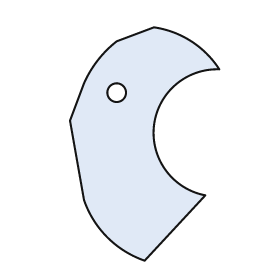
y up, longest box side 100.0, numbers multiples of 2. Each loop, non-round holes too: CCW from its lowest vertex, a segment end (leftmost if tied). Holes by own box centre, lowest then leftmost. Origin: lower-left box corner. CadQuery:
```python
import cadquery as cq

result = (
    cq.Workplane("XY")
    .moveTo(32.0, 0.0)
    .lineTo(58.0, 28.0)
    .threePointArc((36.0, 58.0), (64.0, 82.0))
    .threePointArc((52.0, 94.0), (36.0, 100.0))
    .lineTo(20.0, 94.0)
    .threePointArc((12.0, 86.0), (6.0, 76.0))
    .lineTo(0.0, 60.0)
    .lineTo(6.0, 26.0)
    .threePointArc((16.0, 10.0), (32.0, 0.0))
    .close()
    .moveTo(20.0, 72.0)
    .circle(4.0)
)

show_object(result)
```